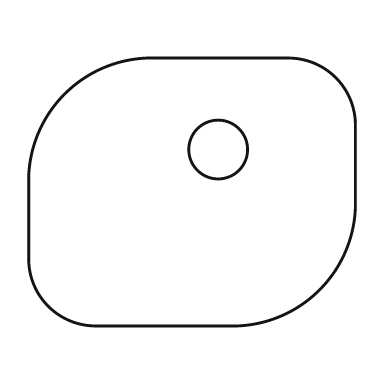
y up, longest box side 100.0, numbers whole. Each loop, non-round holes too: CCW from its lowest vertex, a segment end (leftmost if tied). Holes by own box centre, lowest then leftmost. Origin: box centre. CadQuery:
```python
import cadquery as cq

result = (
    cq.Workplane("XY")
    .moveTo(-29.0, -41.0)
    .lineTo(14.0, -41.0)
    .threePointArc((39.0, -30.0), (50.0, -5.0))
    .lineTo(50.0, 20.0)
    .threePointArc((44.0, 35.0), (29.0, 41.0))
    .lineTo(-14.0, 41.0)
    .threePointArc((-39.0, 30.0), (-50.0, 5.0))
    .lineTo(-50.0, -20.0)
    .threePointArc((-44.0, -35.0), (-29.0, -41.0))
    .close()
    .moveTo(8.0, 13.0)
    .circle(9.0)
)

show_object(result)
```